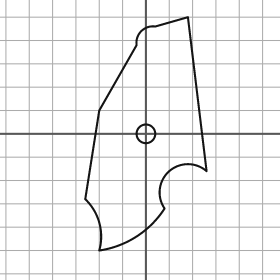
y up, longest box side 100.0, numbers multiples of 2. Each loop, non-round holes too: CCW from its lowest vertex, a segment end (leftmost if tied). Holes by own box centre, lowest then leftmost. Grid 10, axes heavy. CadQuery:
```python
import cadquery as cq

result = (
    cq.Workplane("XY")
    .moveTo(-20.0, -50.0)
    .threePointArc((-4.0, -44.0), (8.0, -32.0))
    .threePointArc((10.0, -16.0), (26.0, -16.0))
    .lineTo(18.0, 50.0)
    .lineTo(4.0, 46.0)
    .threePointArc((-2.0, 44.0), (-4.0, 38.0))
    .lineTo(-20.0, 10.0)
    .lineTo(-26.0, -28.0)
    .threePointArc((-20.0, -38.0), (-20.0, -50.0))
    .close()
    .moveTo(0.0, 0.0)
    .circle(4.0)
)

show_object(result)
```